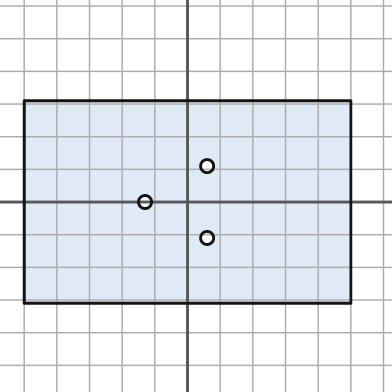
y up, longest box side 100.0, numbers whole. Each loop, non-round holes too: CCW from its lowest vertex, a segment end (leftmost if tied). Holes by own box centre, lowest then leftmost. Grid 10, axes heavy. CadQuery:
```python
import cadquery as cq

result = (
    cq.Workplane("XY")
    .moveTo(-50.0, -31.0)
    .lineTo(50.0, -31.0)
    .lineTo(50.0, 31.0)
    .lineTo(-50.0, 31.0)
    .close()
    .moveTo(6.0, -11.0)
    .circle(2.0)
    .moveTo(-13.0, 0.0)
    .circle(2.0)
    .moveTo(6.0, 11.0)
    .circle(2.0)
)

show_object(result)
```